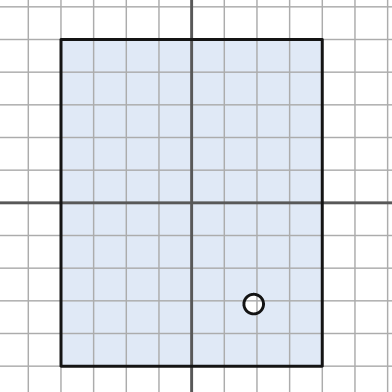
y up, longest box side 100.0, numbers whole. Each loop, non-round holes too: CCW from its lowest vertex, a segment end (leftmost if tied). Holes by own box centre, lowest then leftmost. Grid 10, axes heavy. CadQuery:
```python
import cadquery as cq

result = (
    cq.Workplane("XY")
    .moveTo(-40.0, -50.0)
    .lineTo(40.0, -50.0)
    .lineTo(40.0, 50.0)
    .lineTo(-40.0, 50.0)
    .close()
    .moveTo(19.0, -31.0)
    .circle(3.0)
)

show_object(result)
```